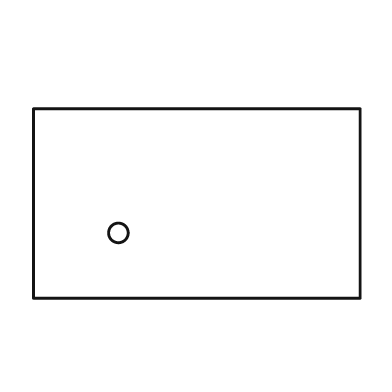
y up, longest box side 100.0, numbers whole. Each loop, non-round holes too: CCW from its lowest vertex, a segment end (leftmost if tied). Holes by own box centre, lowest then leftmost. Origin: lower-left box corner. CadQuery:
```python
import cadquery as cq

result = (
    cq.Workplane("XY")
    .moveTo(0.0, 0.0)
    .lineTo(100.0, 0.0)
    .lineTo(100.0, 58.0)
    .lineTo(0.0, 58.0)
    .close()
    .moveTo(26.0, 20.0)
    .circle(3.0)
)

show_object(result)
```